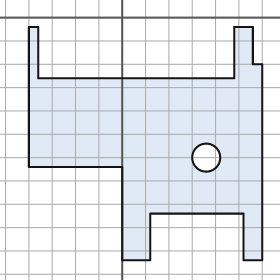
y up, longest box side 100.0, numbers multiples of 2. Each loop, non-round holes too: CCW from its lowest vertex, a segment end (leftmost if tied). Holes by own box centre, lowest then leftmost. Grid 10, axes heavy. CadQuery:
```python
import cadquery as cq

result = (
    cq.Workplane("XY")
    .moveTo(0.0, -104.0)
    .lineTo(12.0, -104.0)
    .lineTo(12.0, -84.0)
    .lineTo(52.0, -84.0)
    .lineTo(52.0, -104.0)
    .lineTo(60.0, -104.0)
    .lineTo(60.0, -20.0)
    .lineTo(56.0, -20.0)
    .lineTo(56.0, -4.0)
    .lineTo(48.0, -4.0)
    .lineTo(48.0, -26.0)
    .lineTo(-36.0, -26.0)
    .lineTo(-36.0, -4.0)
    .lineTo(-40.0, -4.0)
    .lineTo(-40.0, -64.0)
    .lineTo(0.0, -64.0)
    .close()
    .moveTo(36.0, -60.0)
    .circle(6.0)
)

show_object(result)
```